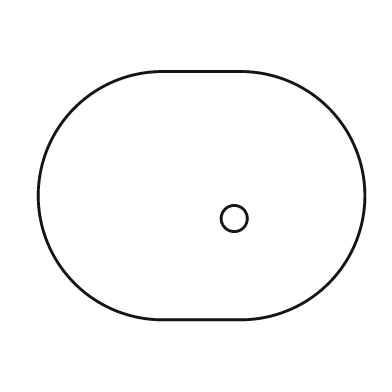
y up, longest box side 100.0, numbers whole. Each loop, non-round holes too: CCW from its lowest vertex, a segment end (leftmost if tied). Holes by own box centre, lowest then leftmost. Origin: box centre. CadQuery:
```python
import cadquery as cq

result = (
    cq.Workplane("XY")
    .moveTo(-12.0, -38.0)
    .lineTo(12.0, -38.0)
    .threePointArc((50.0, 0.0), (12.0, 38.0))
    .lineTo(-12.0, 38.0)
    .threePointArc((-50.0, 0.0), (-12.0, -38.0))
    .close()
    .moveTo(10.0, -7.0)
    .circle(4.0)
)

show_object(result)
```